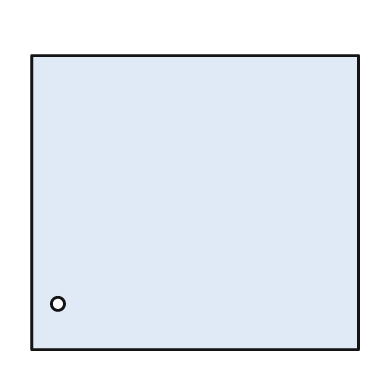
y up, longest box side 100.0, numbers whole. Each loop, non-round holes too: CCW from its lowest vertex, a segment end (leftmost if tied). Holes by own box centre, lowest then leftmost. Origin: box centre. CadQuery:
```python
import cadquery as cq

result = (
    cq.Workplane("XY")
    .moveTo(-50.0, -45.0)
    .lineTo(50.0, -45.0)
    .lineTo(50.0, 45.0)
    .lineTo(-50.0, 45.0)
    .close()
    .moveTo(-42.0, -31.0)
    .circle(2.0)
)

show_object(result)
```